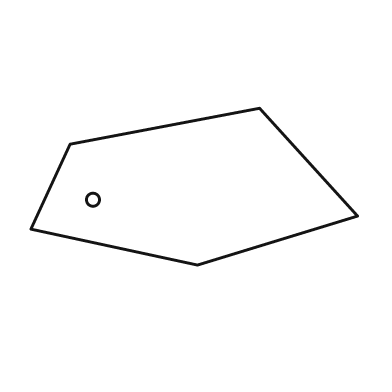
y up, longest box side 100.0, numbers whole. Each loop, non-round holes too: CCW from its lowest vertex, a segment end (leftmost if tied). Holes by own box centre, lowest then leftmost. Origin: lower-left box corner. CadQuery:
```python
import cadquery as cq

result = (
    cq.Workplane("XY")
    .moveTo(51.0, 0.0)
    .lineTo(100.0, 15.0)
    .lineTo(70.0, 48.0)
    .lineTo(12.0, 37.0)
    .lineTo(0.0, 11.0)
    .close()
    .moveTo(19.0, 20.0)
    .circle(2.0)
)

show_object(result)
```